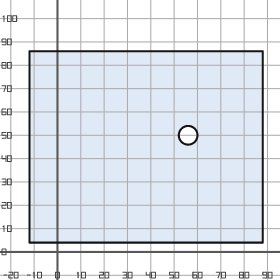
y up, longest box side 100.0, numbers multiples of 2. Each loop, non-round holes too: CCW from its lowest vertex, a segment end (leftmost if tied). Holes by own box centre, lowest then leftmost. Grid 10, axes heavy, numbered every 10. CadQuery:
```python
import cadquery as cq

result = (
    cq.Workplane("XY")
    .moveTo(-12.0, 4.0)
    .lineTo(88.0, 4.0)
    .lineTo(88.0, 86.0)
    .lineTo(-12.0, 86.0)
    .close()
    .moveTo(56.0, 50.0)
    .circle(4.0)
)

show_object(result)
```